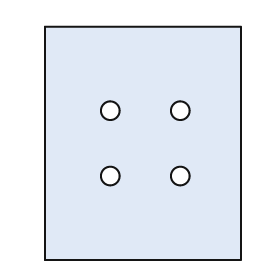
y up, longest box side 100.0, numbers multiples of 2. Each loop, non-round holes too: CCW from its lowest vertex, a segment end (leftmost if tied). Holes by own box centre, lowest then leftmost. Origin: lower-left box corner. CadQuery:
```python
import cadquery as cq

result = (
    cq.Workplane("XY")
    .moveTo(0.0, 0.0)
    .lineTo(84.0, 0.0)
    .lineTo(84.0, 100.0)
    .lineTo(0.0, 100.0)
    .close()
    .moveTo(28.0, 36.0)
    .circle(4.0)
    .moveTo(58.0, 36.0)
    .circle(4.0)
    .moveTo(28.0, 64.0)
    .circle(4.0)
    .moveTo(58.0, 64.0)
    .circle(4.0)
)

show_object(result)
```